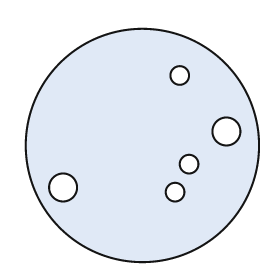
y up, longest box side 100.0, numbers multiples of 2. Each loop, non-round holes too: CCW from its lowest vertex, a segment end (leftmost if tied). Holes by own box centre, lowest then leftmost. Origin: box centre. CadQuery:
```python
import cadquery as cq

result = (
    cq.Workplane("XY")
    .moveTo(0.0, 0.0)
    .circle(50.0)
    .moveTo(14.0, -20.0)
    .circle(4.0)
    .moveTo(-34.0, -18.0)
    .circle(6.0)
    .moveTo(20.0, -8.0)
    .circle(4.0)
    .moveTo(36.0, 6.0)
    .circle(6.0)
    .moveTo(16.0, 30.0)
    .circle(4.0)
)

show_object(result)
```